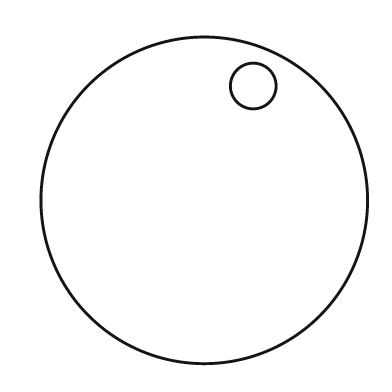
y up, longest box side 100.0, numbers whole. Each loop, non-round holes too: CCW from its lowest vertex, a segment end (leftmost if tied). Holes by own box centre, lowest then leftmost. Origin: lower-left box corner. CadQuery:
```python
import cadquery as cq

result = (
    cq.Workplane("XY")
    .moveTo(50.0, 50.0)
    .circle(50.0)
    .moveTo(65.0, 85.0)
    .circle(7.0)
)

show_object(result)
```